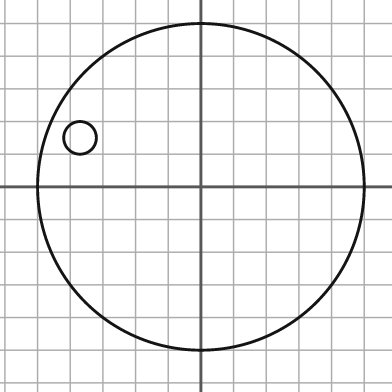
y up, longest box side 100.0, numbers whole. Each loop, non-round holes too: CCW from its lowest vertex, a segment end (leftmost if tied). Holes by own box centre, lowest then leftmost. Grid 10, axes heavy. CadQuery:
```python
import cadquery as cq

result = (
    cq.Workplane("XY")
    .moveTo(0.0, 0.0)
    .circle(50.0)
    .moveTo(-37.0, 15.0)
    .circle(5.0)
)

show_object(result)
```